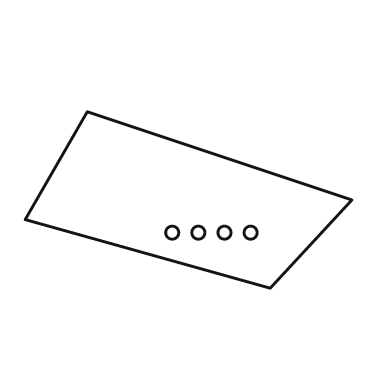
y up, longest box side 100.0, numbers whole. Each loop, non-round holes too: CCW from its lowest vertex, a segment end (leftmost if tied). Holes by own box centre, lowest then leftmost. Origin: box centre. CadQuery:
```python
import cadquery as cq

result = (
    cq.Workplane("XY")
    .moveTo(25.0, -27.0)
    .lineTo(50.0, 0.0)
    .lineTo(-31.0, 27.0)
    .lineTo(-50.0, -6.0)
    .close()
    .moveTo(-5.0, -10.0)
    .circle(2.0)
    .moveTo(3.0, -10.0)
    .circle(2.0)
    .moveTo(11.0, -10.0)
    .circle(2.0)
    .moveTo(19.0, -10.0)
    .circle(2.0)
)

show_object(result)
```